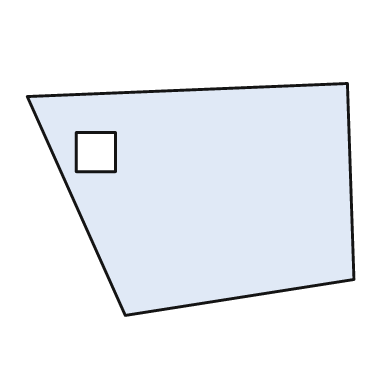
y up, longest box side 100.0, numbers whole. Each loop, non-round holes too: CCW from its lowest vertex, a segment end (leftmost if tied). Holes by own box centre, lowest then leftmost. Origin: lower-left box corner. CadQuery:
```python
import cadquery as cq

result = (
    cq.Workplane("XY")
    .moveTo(30.0, 0.0)
    .lineTo(100.0, 11.0)
    .lineTo(98.0, 71.0)
    .lineTo(0.0, 67.0)
    .close()
    .moveTo(15.0, 44.0)
    .lineTo(27.0, 44.0)
    .lineTo(27.0, 56.0)
    .lineTo(15.0, 56.0)
    .close()
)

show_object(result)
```